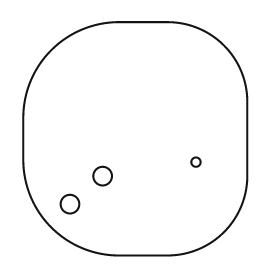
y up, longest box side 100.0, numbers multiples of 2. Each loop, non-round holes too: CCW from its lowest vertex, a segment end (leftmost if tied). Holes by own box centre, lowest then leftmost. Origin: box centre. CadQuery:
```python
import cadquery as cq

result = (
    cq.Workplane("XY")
    .moveTo(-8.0, -50.0)
    .lineTo(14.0, -50.0)
    .threePointArc((38.0, -40.0), (48.0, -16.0))
    .lineTo(48.0, 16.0)
    .threePointArc((38.0, 40.0), (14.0, 50.0))
    .lineTo(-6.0, 50.0)
    .threePointArc((-36.0, 38.0), (-48.0, 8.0))
    .lineTo(-48.0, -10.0)
    .threePointArc((-36.0, -38.0), (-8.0, -50.0))
    .close()
    .moveTo(-28.0, -28.0)
    .circle(4.0)
    .moveTo(-14.0, -16.0)
    .circle(4.0)
    .moveTo(26.0, -10.0)
    .circle(2.0)
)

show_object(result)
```